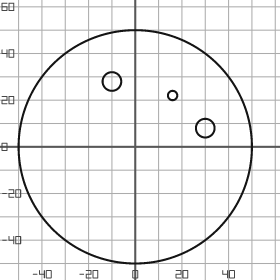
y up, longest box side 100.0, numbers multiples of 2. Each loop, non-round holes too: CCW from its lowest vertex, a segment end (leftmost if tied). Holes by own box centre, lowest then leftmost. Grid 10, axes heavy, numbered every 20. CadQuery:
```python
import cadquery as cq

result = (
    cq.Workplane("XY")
    .moveTo(0.0, 0.0)
    .circle(50.0)
    .moveTo(30.0, 8.0)
    .circle(4.0)
    .moveTo(16.0, 22.0)
    .circle(2.0)
    .moveTo(-10.0, 28.0)
    .circle(4.0)
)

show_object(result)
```